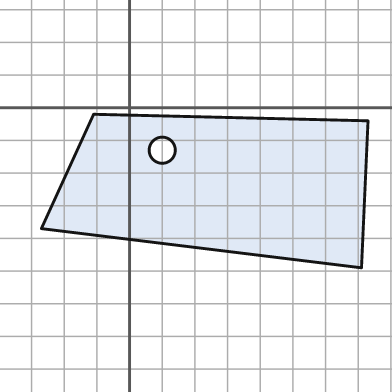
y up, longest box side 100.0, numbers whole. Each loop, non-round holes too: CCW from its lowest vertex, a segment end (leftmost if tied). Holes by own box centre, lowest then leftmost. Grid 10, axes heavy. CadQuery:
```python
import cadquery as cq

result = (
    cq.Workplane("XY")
    .moveTo(71.0, -49.0)
    .lineTo(73.0, -4.0)
    .lineTo(-11.0, -2.0)
    .lineTo(-27.0, -37.0)
    .close()
    .moveTo(10.0, -13.0)
    .circle(4.0)
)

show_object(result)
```